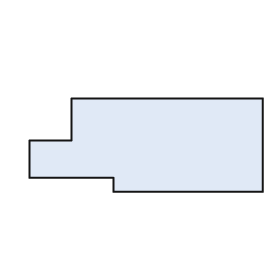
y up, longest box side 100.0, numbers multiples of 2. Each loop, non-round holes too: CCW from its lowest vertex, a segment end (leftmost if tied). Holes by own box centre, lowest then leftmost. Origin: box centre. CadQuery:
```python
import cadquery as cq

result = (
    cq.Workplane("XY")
    .moveTo(-14.0, -20.0)
    .lineTo(50.0, -20.0)
    .lineTo(50.0, 20.0)
    .lineTo(-32.0, 20.0)
    .lineTo(-32.0, 2.0)
    .lineTo(-50.0, 2.0)
    .lineTo(-50.0, -14.0)
    .lineTo(-14.0, -14.0)
    .close()
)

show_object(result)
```